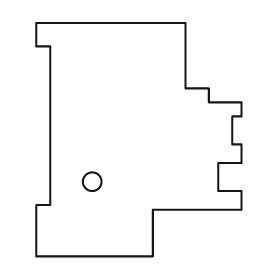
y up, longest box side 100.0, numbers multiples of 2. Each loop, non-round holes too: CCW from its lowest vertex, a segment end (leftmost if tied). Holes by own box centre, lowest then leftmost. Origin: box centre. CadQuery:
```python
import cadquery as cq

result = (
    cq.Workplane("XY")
    .moveTo(-44.0, -50.0)
    .lineTo(6.0, -50.0)
    .lineTo(6.0, -30.0)
    .lineTo(44.0, -30.0)
    .lineTo(44.0, -22.0)
    .lineTo(34.0, -22.0)
    .lineTo(34.0, -10.0)
    .lineTo(44.0, -10.0)
    .lineTo(44.0, -2.0)
    .lineTo(40.0, -2.0)
    .lineTo(40.0, 10.0)
    .lineTo(44.0, 10.0)
    .lineTo(44.0, 16.0)
    .lineTo(30.0, 16.0)
    .lineTo(30.0, 22.0)
    .lineTo(20.0, 22.0)
    .lineTo(20.0, 50.0)
    .lineTo(-44.0, 50.0)
    .lineTo(-44.0, 40.0)
    .lineTo(-38.0, 40.0)
    .lineTo(-38.0, -28.0)
    .lineTo(-44.0, -28.0)
    .close()
    .moveTo(-20.0, -18.0)
    .circle(4.0)
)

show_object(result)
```